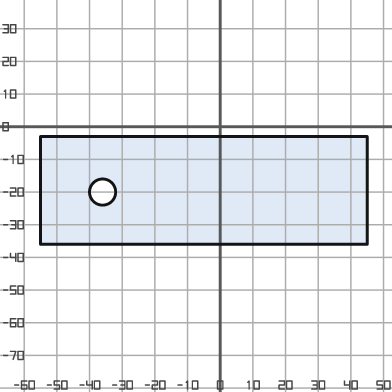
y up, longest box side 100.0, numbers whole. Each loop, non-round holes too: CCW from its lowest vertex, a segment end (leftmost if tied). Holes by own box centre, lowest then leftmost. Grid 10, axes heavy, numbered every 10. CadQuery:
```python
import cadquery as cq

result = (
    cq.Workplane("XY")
    .moveTo(-55.0, -36.0)
    .lineTo(45.0, -36.0)
    .lineTo(45.0, -3.0)
    .lineTo(-55.0, -3.0)
    .close()
    .moveTo(-36.0, -20.0)
    .circle(4.0)
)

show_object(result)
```